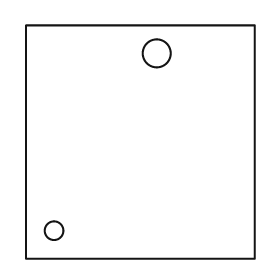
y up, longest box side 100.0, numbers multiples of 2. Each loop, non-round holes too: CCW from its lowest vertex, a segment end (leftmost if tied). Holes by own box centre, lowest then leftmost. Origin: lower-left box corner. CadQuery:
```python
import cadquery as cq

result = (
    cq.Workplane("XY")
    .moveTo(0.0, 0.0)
    .lineTo(98.0, 0.0)
    .lineTo(98.0, 100.0)
    .lineTo(0.0, 100.0)
    .close()
    .moveTo(12.0, 12.0)
    .circle(4.0)
    .moveTo(56.0, 88.0)
    .circle(6.0)
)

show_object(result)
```